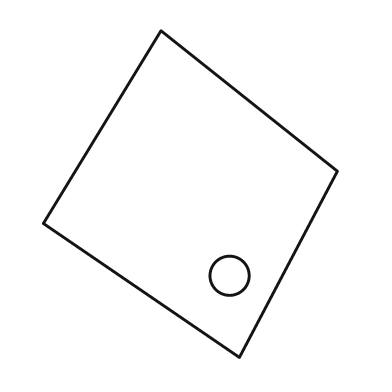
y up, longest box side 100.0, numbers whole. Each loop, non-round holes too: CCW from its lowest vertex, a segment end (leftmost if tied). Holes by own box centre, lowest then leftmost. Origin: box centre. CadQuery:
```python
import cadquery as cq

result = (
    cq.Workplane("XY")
    .moveTo(15.0, -50.0)
    .lineTo(45.0, 7.0)
    .lineTo(-9.0, 50.0)
    .lineTo(-45.0, -9.0)
    .close()
    .moveTo(12.0, -25.0)
    .circle(6.0)
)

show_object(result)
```